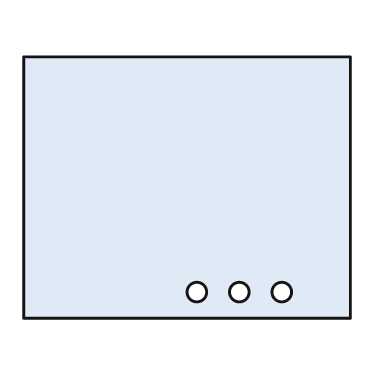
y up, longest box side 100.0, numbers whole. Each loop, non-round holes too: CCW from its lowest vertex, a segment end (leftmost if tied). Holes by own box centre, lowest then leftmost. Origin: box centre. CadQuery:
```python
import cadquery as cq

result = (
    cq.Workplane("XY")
    .moveTo(-50.0, -40.0)
    .lineTo(50.0, -40.0)
    .lineTo(50.0, 40.0)
    .lineTo(-50.0, 40.0)
    .close()
    .moveTo(3.0, -32.0)
    .circle(3.0)
    .moveTo(16.0, -32.0)
    .circle(3.0)
    .moveTo(29.0, -32.0)
    .circle(3.0)
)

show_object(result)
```